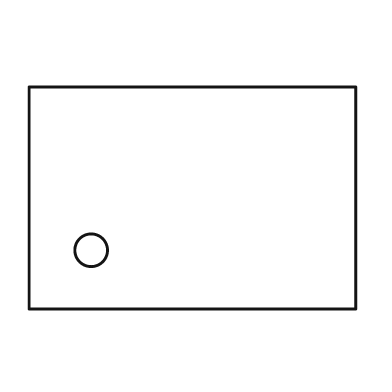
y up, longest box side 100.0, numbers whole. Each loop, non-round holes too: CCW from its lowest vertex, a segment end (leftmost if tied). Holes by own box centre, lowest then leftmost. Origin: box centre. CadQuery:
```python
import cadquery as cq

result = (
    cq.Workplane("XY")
    .moveTo(-50.0, -34.0)
    .lineTo(50.0, -34.0)
    .lineTo(50.0, 34.0)
    .lineTo(-50.0, 34.0)
    .close()
    .moveTo(-31.0, -16.0)
    .circle(5.0)
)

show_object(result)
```